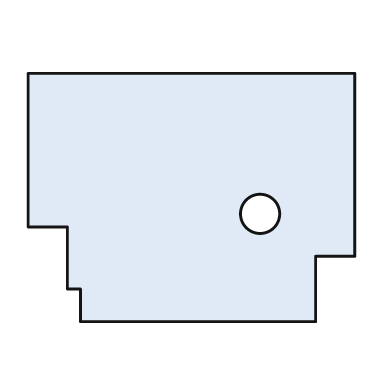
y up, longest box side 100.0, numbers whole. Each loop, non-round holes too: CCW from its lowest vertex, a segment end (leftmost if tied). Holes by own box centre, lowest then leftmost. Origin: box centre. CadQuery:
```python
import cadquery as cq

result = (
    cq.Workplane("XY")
    .moveTo(-34.0, -38.0)
    .lineTo(38.0, -38.0)
    .lineTo(38.0, -18.0)
    .lineTo(50.0, -18.0)
    .lineTo(50.0, 38.0)
    .lineTo(-50.0, 38.0)
    .lineTo(-50.0, -9.0)
    .lineTo(-38.0, -9.0)
    .lineTo(-38.0, -28.0)
    .lineTo(-34.0, -28.0)
    .close()
    .moveTo(21.0, -5.0)
    .circle(6.0)
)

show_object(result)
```